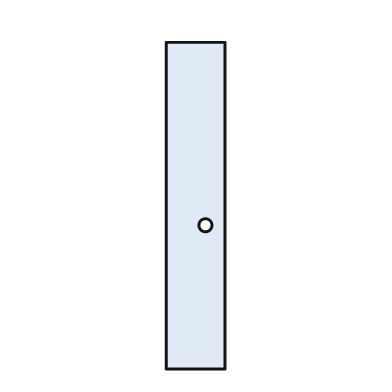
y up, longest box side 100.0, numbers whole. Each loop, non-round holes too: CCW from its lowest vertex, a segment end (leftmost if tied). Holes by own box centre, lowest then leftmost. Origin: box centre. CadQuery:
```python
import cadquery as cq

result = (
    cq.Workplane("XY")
    .moveTo(-9.0, -50.0)
    .lineTo(9.0, -50.0)
    .lineTo(9.0, 50.0)
    .lineTo(-9.0, 50.0)
    .close()
    .moveTo(3.0, -6.0)
    .circle(2.0)
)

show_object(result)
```